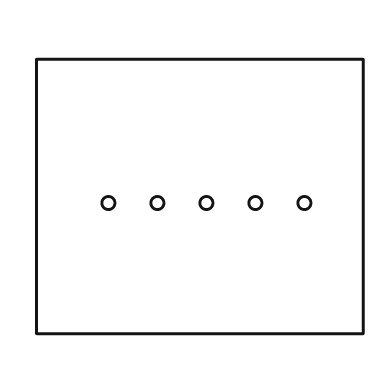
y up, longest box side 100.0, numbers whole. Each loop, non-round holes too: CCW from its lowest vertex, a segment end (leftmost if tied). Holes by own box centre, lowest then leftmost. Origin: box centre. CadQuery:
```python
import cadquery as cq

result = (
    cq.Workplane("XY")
    .moveTo(-50.0, -42.0)
    .lineTo(50.0, -42.0)
    .lineTo(50.0, 42.0)
    .lineTo(-50.0, 42.0)
    .close()
    .moveTo(-28.0, -2.0)
    .circle(2.0)
    .moveTo(-13.0, -2.0)
    .circle(2.0)
    .moveTo(2.0, -2.0)
    .circle(2.0)
    .moveTo(17.0, -2.0)
    .circle(2.0)
    .moveTo(32.0, -2.0)
    .circle(2.0)
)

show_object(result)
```